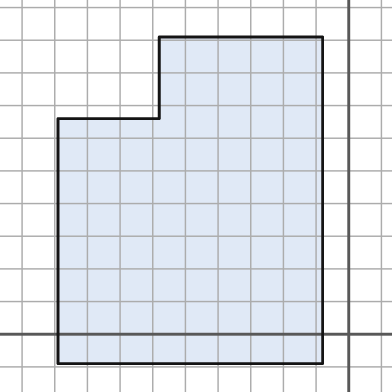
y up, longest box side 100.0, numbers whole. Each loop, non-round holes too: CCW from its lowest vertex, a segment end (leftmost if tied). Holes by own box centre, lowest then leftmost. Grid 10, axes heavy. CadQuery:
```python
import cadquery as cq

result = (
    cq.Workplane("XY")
    .moveTo(-89.0, -9.0)
    .lineTo(-8.0, -9.0)
    .lineTo(-8.0, 91.0)
    .lineTo(-58.0, 91.0)
    .lineTo(-58.0, 66.0)
    .lineTo(-89.0, 66.0)
    .close()
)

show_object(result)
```